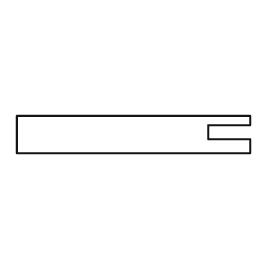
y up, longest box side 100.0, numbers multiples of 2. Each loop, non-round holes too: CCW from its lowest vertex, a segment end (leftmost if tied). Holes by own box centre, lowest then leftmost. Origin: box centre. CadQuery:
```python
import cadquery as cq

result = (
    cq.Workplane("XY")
    .moveTo(-50.0, -8.0)
    .lineTo(50.0, -8.0)
    .lineTo(50.0, -2.0)
    .lineTo(32.0, -2.0)
    .lineTo(32.0, 4.0)
    .lineTo(50.0, 4.0)
    .lineTo(50.0, 8.0)
    .lineTo(-50.0, 8.0)
    .close()
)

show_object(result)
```